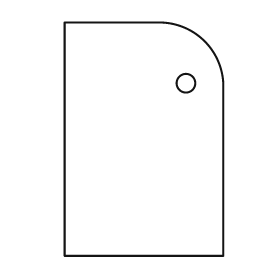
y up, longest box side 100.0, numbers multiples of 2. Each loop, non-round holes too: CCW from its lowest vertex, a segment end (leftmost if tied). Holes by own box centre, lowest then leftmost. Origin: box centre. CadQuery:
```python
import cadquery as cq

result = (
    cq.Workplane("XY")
    .moveTo(-34.0, -50.0)
    .lineTo(34.0, -50.0)
    .lineTo(34.0, 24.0)
    .threePointArc((26.0, 42.0), (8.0, 50.0))
    .lineTo(-34.0, 50.0)
    .close()
    .moveTo(18.0, 24.0)
    .circle(4.0)
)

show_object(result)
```